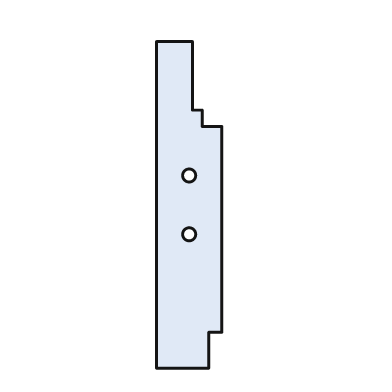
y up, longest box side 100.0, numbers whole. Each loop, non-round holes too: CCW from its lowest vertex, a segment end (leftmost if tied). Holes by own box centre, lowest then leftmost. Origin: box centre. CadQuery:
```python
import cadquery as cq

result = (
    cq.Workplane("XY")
    .moveTo(-10.0, -50.0)
    .lineTo(6.0, -50.0)
    .lineTo(6.0, -39.0)
    .lineTo(10.0, -39.0)
    .lineTo(10.0, 24.0)
    .lineTo(4.0, 24.0)
    .lineTo(4.0, 29.0)
    .lineTo(1.0, 29.0)
    .lineTo(1.0, 50.0)
    .lineTo(-10.0, 50.0)
    .close()
    .moveTo(0.0, -9.0)
    .circle(2.0)
    .moveTo(0.0, 9.0)
    .circle(2.0)
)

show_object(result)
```